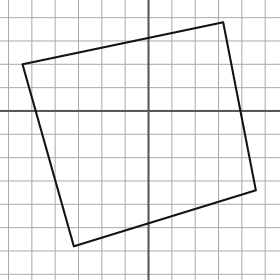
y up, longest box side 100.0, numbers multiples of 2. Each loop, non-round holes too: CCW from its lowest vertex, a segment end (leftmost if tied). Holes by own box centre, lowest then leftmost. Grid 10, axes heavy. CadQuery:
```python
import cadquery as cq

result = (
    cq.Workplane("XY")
    .moveTo(-32.0, -58.0)
    .lineTo(46.0, -34.0)
    .lineTo(32.0, 38.0)
    .lineTo(-54.0, 20.0)
    .close()
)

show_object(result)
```